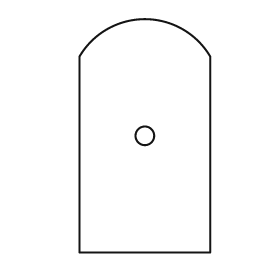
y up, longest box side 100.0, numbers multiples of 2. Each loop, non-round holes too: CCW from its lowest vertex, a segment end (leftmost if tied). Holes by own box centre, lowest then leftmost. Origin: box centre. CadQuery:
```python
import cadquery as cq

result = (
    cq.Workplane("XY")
    .moveTo(-28.0, -50.0)
    .lineTo(28.0, -50.0)
    .lineTo(28.0, 34.0)
    .threePointArc((0.0, 50.0), (-28.0, 34.0))
    .close()
    .moveTo(0.0, 0.0)
    .circle(4.0)
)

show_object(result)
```